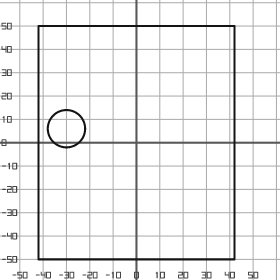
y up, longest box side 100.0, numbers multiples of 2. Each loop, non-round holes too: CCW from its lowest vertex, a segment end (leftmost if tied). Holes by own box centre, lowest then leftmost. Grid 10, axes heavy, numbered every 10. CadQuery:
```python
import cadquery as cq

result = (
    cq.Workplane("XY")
    .moveTo(-42.0, -50.0)
    .lineTo(42.0, -50.0)
    .lineTo(42.0, 50.0)
    .lineTo(-42.0, 50.0)
    .close()
    .moveTo(-30.0, 6.0)
    .circle(8.0)
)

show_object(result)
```